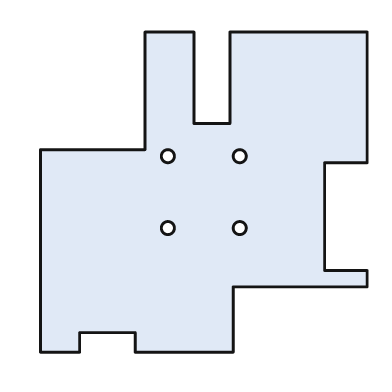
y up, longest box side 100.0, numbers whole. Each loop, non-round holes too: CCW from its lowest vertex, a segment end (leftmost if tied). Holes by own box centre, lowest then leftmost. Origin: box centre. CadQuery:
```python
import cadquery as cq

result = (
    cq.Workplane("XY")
    .moveTo(-50.0, -49.0)
    .lineTo(-38.0, -49.0)
    .lineTo(-38.0, -43.0)
    .lineTo(-21.0, -43.0)
    .lineTo(-21.0, -49.0)
    .lineTo(9.0, -49.0)
    .lineTo(9.0, -29.0)
    .lineTo(50.0, -29.0)
    .lineTo(50.0, -24.0)
    .lineTo(37.0, -24.0)
    .lineTo(37.0, 9.0)
    .lineTo(50.0, 9.0)
    .lineTo(50.0, 49.0)
    .lineTo(8.0, 49.0)
    .lineTo(8.0, 21.0)
    .lineTo(-3.0, 21.0)
    .lineTo(-3.0, 49.0)
    .lineTo(-18.0, 49.0)
    .lineTo(-18.0, 13.0)
    .lineTo(-50.0, 13.0)
    .close()
    .moveTo(-11.0, -11.0)
    .circle(2.0)
    .moveTo(11.0, -11.0)
    .circle(2.0)
    .moveTo(-11.0, 11.0)
    .circle(2.0)
    .moveTo(11.0, 11.0)
    .circle(2.0)
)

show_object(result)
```